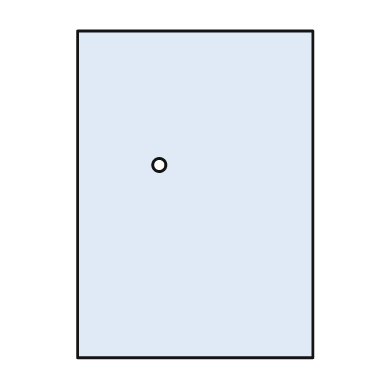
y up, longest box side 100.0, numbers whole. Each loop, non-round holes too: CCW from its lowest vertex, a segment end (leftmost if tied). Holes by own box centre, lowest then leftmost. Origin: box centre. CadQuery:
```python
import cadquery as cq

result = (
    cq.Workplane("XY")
    .moveTo(-36.0, -50.0)
    .lineTo(36.0, -50.0)
    .lineTo(36.0, 50.0)
    .lineTo(-36.0, 50.0)
    .close()
    .moveTo(-11.0, 9.0)
    .circle(2.0)
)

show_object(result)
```